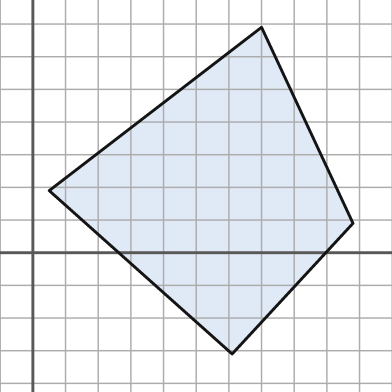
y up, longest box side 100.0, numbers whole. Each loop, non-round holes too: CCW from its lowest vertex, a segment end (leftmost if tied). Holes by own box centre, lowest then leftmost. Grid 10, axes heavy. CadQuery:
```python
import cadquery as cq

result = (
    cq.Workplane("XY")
    .moveTo(61.0, -31.0)
    .lineTo(98.0, 9.0)
    .lineTo(70.0, 69.0)
    .lineTo(5.0, 19.0)
    .close()
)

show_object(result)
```